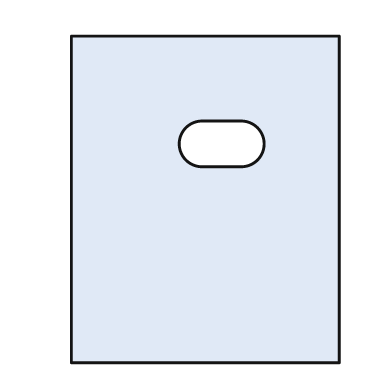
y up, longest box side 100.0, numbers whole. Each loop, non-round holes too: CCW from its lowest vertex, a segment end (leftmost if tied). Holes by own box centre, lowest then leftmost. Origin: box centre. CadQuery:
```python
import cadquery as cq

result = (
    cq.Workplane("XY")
    .moveTo(-41.0, -50.0)
    .lineTo(41.0, -50.0)
    .lineTo(41.0, 50.0)
    .lineTo(-41.0, 50.0)
    .close()
    .moveTo(-1.0, 10.0)
    .lineTo(11.0, 10.0)
    .threePointArc((18.0, 17.0), (11.0, 24.0))
    .lineTo(-1.0, 24.0)
    .threePointArc((-8.0, 17.0), (-1.0, 10.0))
    .close()
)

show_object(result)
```